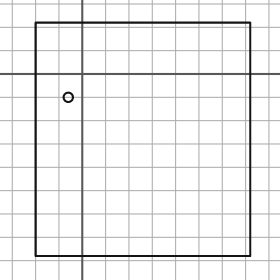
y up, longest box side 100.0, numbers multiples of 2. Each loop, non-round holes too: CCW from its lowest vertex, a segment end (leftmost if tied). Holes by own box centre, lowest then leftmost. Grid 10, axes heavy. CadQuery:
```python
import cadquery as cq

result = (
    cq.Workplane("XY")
    .moveTo(-20.0, -78.0)
    .lineTo(72.0, -78.0)
    .lineTo(72.0, 22.0)
    .lineTo(-20.0, 22.0)
    .close()
    .moveTo(-6.0, -10.0)
    .circle(2.0)
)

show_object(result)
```